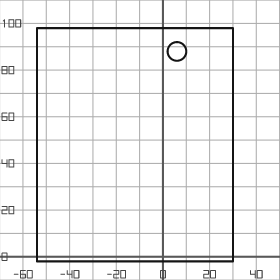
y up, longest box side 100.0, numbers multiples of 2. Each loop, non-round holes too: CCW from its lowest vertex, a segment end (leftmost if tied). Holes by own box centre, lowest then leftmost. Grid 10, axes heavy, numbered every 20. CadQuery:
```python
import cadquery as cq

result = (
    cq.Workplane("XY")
    .moveTo(-54.0, -2.0)
    .lineTo(30.0, -2.0)
    .lineTo(30.0, 98.0)
    .lineTo(-54.0, 98.0)
    .close()
    .moveTo(6.0, 88.0)
    .circle(4.0)
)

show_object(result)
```